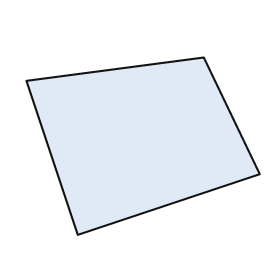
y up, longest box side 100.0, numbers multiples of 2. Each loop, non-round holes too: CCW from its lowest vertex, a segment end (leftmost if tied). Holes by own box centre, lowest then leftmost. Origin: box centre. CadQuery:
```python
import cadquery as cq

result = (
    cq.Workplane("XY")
    .moveTo(-28.0, -38.0)
    .lineTo(50.0, -12.0)
    .lineTo(26.0, 38.0)
    .lineTo(-50.0, 28.0)
    .close()
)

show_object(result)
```